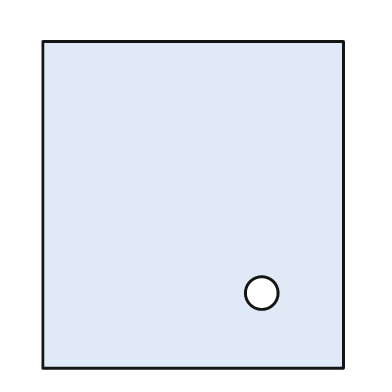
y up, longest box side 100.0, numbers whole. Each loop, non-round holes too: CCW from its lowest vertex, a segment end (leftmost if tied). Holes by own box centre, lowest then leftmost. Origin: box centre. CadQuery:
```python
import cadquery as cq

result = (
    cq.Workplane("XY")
    .moveTo(-46.0, -50.0)
    .lineTo(46.0, -50.0)
    .lineTo(46.0, 50.0)
    .lineTo(-46.0, 50.0)
    .close()
    .moveTo(21.0, -27.0)
    .circle(5.0)
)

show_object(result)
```